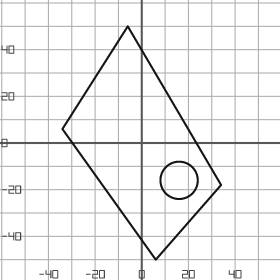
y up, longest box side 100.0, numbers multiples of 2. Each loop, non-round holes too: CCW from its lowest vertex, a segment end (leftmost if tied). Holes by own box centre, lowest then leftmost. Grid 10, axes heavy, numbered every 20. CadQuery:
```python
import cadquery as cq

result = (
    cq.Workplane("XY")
    .moveTo(6.0, -50.0)
    .lineTo(34.0, -18.0)
    .lineTo(-6.0, 50.0)
    .lineTo(-34.0, 6.0)
    .close()
    .moveTo(16.0, -16.0)
    .circle(8.0)
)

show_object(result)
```